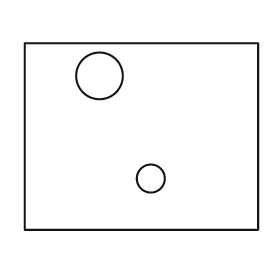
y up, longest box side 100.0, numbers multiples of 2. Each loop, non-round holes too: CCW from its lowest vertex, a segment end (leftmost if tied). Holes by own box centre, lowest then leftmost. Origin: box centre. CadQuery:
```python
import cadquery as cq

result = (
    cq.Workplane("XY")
    .moveTo(-50.0, -40.0)
    .lineTo(50.0, -40.0)
    .lineTo(50.0, 40.0)
    .lineTo(-50.0, 40.0)
    .close()
    .moveTo(4.0, -18.0)
    .circle(6.0)
    .moveTo(-18.0, 26.0)
    .circle(10.0)
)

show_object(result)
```